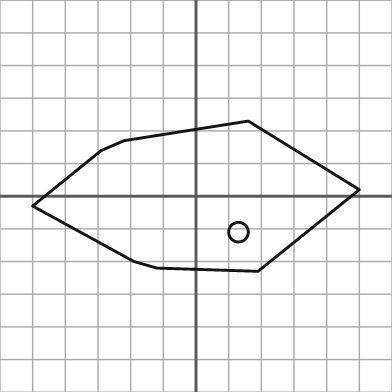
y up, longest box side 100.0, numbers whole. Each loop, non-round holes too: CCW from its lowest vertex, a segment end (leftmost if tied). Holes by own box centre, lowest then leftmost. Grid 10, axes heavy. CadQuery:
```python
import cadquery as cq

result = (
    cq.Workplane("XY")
    .moveTo(19.0, -23.0)
    .lineTo(50.0, 2.0)
    .lineTo(16.0, 23.0)
    .lineTo(-22.0, 17.0)
    .lineTo(-29.0, 14.0)
    .lineTo(-50.0, -3.0)
    .lineTo(-19.0, -20.0)
    .lineTo(-12.0, -22.0)
    .close()
    .moveTo(13.0, -11.0)
    .circle(3.0)
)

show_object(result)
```